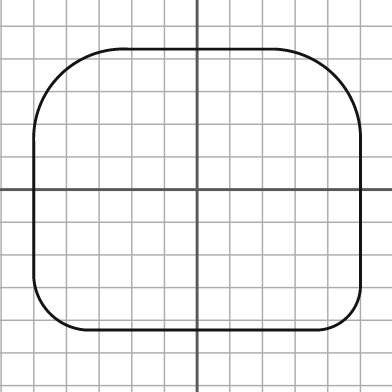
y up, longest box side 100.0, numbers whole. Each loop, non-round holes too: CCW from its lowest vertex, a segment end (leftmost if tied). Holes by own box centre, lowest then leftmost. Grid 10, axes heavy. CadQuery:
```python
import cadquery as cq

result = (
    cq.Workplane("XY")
    .moveTo(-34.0, -43.0)
    .lineTo(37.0, -43.0)
    .threePointArc((46.0, -39.0), (50.0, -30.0))
    .lineTo(50.0, 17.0)
    .threePointArc((42.0, 35.0), (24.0, 43.0))
    .lineTo(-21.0, 43.0)
    .threePointArc((-42.0, 35.0), (-50.0, 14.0))
    .lineTo(-50.0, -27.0)
    .threePointArc((-45.0, -38.0), (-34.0, -43.0))
    .close()
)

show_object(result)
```